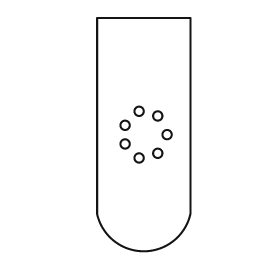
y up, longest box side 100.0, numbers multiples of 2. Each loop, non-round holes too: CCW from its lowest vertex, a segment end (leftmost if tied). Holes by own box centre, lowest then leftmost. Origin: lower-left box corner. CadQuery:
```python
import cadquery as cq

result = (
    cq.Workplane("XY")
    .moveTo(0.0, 16.0)
    .threePointArc((20.0, 0.0), (40.0, 16.0))
    .lineTo(40.0, 100.0)
    .lineTo(0.0, 100.0)
    .close()
    .moveTo(18.0, 40.0)
    .circle(2.0)
    .moveTo(26.0, 42.0)
    .circle(2.0)
    .moveTo(12.0, 46.0)
    .circle(2.0)
    .moveTo(30.0, 50.0)
    .circle(2.0)
    .moveTo(12.0, 54.0)
    .circle(2.0)
    .moveTo(26.0, 58.0)
    .circle(2.0)
    .moveTo(18.0, 60.0)
    .circle(2.0)
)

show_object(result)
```